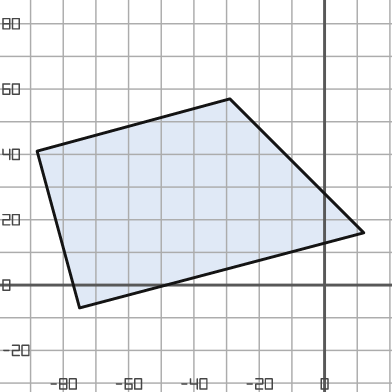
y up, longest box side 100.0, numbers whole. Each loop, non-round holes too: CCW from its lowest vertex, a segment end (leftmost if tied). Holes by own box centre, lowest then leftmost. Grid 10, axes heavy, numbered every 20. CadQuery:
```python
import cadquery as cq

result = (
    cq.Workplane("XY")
    .moveTo(-75.0, -7.0)
    .lineTo(12.0, 16.0)
    .lineTo(-29.0, 57.0)
    .lineTo(-88.0, 41.0)
    .close()
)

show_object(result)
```